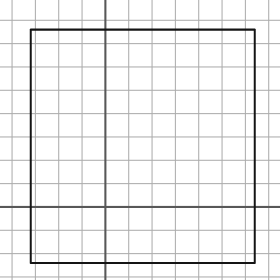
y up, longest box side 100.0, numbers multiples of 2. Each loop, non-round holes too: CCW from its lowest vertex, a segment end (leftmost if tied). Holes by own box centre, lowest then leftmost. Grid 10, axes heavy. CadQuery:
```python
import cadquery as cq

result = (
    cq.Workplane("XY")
    .moveTo(-32.0, -24.0)
    .lineTo(64.0, -24.0)
    .lineTo(64.0, 76.0)
    .lineTo(-32.0, 76.0)
    .close()
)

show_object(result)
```